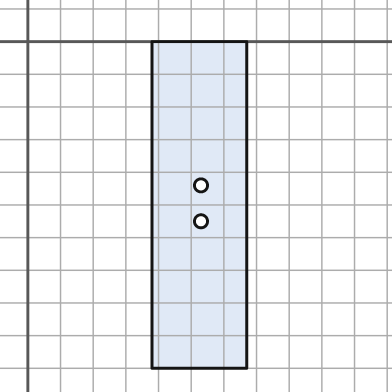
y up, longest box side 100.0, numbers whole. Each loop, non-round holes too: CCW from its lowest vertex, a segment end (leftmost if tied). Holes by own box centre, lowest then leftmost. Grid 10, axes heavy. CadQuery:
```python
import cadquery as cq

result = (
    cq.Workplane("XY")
    .moveTo(38.0, -100.0)
    .lineTo(67.0, -100.0)
    .lineTo(67.0, 0.0)
    .lineTo(38.0, 0.0)
    .close()
    .moveTo(53.0, -55.0)
    .circle(2.0)
    .moveTo(53.0, -44.0)
    .circle(2.0)
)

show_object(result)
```